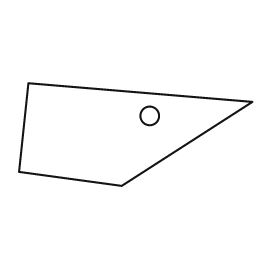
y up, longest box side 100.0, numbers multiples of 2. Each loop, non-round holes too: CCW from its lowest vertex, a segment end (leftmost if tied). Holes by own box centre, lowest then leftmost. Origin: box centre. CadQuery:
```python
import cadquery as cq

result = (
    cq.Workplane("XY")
    .moveTo(-6.0, -22.0)
    .lineTo(50.0, 14.0)
    .lineTo(-46.0, 22.0)
    .lineTo(-50.0, -16.0)
    .close()
    .moveTo(6.0, 8.0)
    .circle(4.0)
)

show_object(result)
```